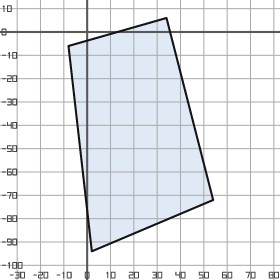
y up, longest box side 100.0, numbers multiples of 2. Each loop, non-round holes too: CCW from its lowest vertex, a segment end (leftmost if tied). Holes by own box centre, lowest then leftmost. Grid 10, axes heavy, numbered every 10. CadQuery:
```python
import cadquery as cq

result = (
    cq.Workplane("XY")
    .moveTo(2.0, -94.0)
    .lineTo(54.0, -72.0)
    .lineTo(34.0, 6.0)
    .lineTo(-8.0, -6.0)
    .close()
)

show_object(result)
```